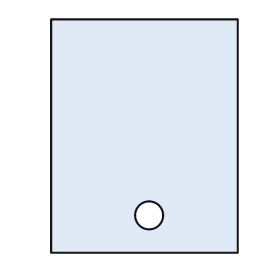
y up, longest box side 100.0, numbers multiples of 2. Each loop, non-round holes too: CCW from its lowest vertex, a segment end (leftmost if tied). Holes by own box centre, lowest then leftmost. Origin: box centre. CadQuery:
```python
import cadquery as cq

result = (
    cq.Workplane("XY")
    .moveTo(-40.0, -50.0)
    .lineTo(40.0, -50.0)
    .lineTo(40.0, 50.0)
    .lineTo(-40.0, 50.0)
    .close()
    .moveTo(2.0, -34.0)
    .circle(6.0)
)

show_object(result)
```